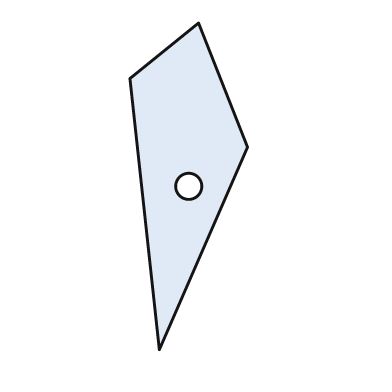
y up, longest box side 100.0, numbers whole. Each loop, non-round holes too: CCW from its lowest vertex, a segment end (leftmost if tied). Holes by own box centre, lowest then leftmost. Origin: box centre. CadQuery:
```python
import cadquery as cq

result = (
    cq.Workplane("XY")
    .moveTo(-9.0, -50.0)
    .lineTo(18.0, 12.0)
    .lineTo(3.0, 50.0)
    .lineTo(-18.0, 33.0)
    .close()
    .moveTo(0.0, 0.0)
    .circle(4.0)
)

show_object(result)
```